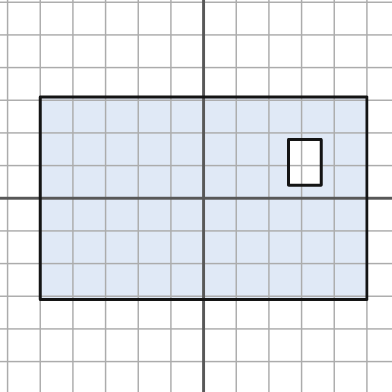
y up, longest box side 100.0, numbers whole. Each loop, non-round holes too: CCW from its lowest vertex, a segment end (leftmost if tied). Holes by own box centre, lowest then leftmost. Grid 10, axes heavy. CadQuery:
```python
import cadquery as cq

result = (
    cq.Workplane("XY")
    .moveTo(-50.0, -31.0)
    .lineTo(50.0, -31.0)
    .lineTo(50.0, 31.0)
    .lineTo(-50.0, 31.0)
    .close()
    .moveTo(26.0, 4.0)
    .lineTo(36.0, 4.0)
    .lineTo(36.0, 18.0)
    .lineTo(26.0, 18.0)
    .close()
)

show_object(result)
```